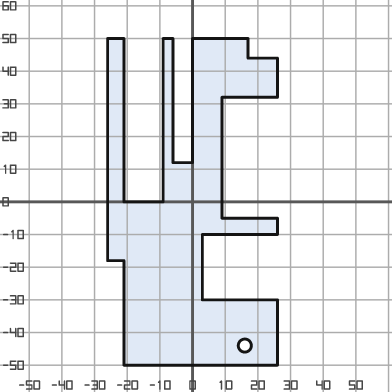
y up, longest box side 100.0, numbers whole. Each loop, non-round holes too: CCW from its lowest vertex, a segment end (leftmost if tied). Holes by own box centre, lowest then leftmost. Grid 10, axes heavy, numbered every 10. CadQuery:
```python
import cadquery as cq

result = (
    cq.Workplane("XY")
    .moveTo(-21.0, -50.0)
    .lineTo(26.0, -50.0)
    .lineTo(26.0, -30.0)
    .lineTo(3.0, -30.0)
    .lineTo(3.0, -10.0)
    .lineTo(26.0, -10.0)
    .lineTo(26.0, -5.0)
    .lineTo(9.0, -5.0)
    .lineTo(9.0, 32.0)
    .lineTo(26.0, 32.0)
    .lineTo(26.0, 44.0)
    .lineTo(17.0, 44.0)
    .lineTo(17.0, 50.0)
    .lineTo(0.0, 50.0)
    .lineTo(0.0, 12.0)
    .lineTo(-6.0, 12.0)
    .lineTo(-6.0, 50.0)
    .lineTo(-9.0, 50.0)
    .lineTo(-9.0, 0.0)
    .lineTo(-21.0, 0.0)
    .lineTo(-21.0, 50.0)
    .lineTo(-26.0, 50.0)
    .lineTo(-26.0, -18.0)
    .lineTo(-21.0, -18.0)
    .close()
    .moveTo(16.0, -44.0)
    .circle(2.0)
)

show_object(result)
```